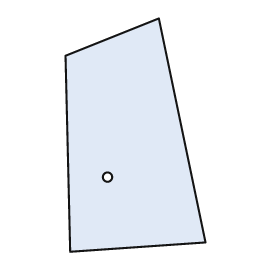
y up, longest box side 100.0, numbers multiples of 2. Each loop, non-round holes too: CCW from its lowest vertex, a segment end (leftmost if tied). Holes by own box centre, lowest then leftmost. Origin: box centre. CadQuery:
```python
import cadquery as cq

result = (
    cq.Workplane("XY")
    .moveTo(-28.0, -50.0)
    .lineTo(30.0, -46.0)
    .lineTo(10.0, 50.0)
    .lineTo(-30.0, 34.0)
    .close()
    .moveTo(-12.0, -18.0)
    .circle(2.0)
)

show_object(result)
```